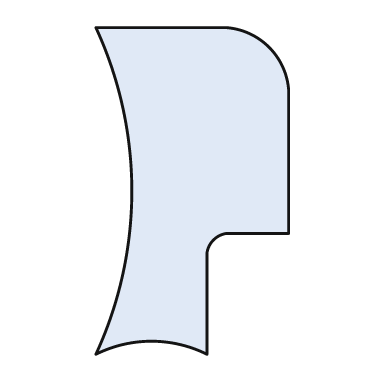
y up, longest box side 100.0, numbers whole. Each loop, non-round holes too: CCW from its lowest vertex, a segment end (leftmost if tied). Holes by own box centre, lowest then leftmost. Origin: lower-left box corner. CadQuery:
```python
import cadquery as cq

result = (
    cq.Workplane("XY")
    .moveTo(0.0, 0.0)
    .threePointArc((17.0, 4.0), (34.0, 0.0))
    .lineTo(34.0, 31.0)
    .threePointArc((36.0, 35.0), (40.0, 37.0))
    .lineTo(59.0, 37.0)
    .lineTo(59.0, 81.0)
    .threePointArc((53.0, 94.0), (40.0, 100.0))
    .lineTo(0.0, 100.0)
    .threePointArc((11.0, 50.0), (0.0, 0.0))
    .close()
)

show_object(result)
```